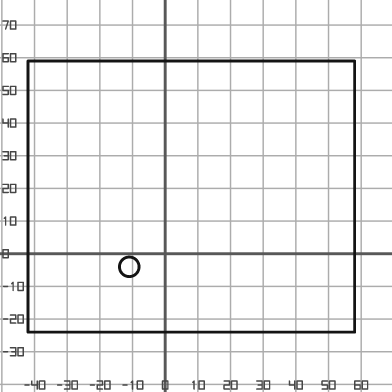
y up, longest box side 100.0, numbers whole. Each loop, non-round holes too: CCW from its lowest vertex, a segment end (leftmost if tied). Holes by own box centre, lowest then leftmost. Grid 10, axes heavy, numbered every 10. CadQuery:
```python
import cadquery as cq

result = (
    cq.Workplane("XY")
    .moveTo(-42.0, -24.0)
    .lineTo(58.0, -24.0)
    .lineTo(58.0, 59.0)
    .lineTo(-42.0, 59.0)
    .close()
    .moveTo(-11.0, -4.0)
    .circle(3.0)
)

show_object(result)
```